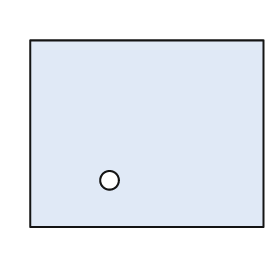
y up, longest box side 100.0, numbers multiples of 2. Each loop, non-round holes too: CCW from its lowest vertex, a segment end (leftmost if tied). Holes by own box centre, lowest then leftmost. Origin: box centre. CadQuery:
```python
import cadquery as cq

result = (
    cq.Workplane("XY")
    .moveTo(-50.0, -40.0)
    .lineTo(50.0, -40.0)
    .lineTo(50.0, 40.0)
    .lineTo(-50.0, 40.0)
    .close()
    .moveTo(-16.0, -20.0)
    .circle(4.0)
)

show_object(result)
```